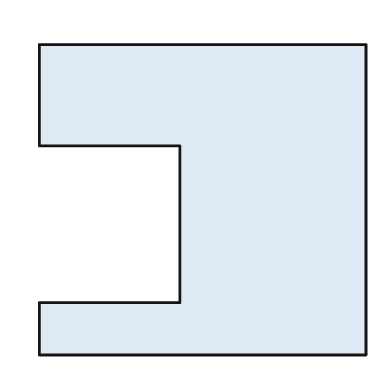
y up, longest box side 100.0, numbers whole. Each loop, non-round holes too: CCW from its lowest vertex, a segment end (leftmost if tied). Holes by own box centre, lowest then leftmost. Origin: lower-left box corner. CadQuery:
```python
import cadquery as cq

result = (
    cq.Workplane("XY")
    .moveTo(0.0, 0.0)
    .lineTo(100.0, 0.0)
    .lineTo(100.0, 95.0)
    .lineTo(0.0, 95.0)
    .lineTo(0.0, 64.0)
    .lineTo(43.0, 64.0)
    .lineTo(43.0, 16.0)
    .lineTo(0.0, 16.0)
    .close()
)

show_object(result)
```